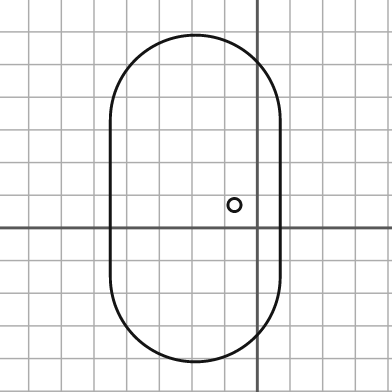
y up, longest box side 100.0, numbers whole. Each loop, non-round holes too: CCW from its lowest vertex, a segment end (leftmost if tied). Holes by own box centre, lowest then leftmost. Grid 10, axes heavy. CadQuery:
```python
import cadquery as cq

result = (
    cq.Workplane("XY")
    .moveTo(-45.0, -15.0)
    .threePointArc((-19.0, -41.0), (7.0, -15.0))
    .lineTo(7.0, 33.0)
    .threePointArc((-19.0, 59.0), (-45.0, 33.0))
    .close()
    .moveTo(-7.0, 7.0)
    .circle(2.0)
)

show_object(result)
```